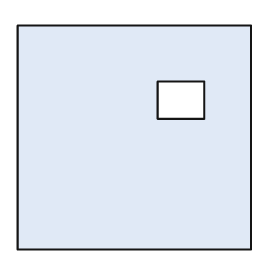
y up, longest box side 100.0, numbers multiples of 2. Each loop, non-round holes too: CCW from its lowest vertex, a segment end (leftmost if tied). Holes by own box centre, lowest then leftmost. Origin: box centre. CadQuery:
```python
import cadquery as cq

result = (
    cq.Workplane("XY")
    .moveTo(-50.0, -48.0)
    .lineTo(50.0, -48.0)
    .lineTo(50.0, 48.0)
    .lineTo(-50.0, 48.0)
    .close()
    .moveTo(10.0, 8.0)
    .lineTo(30.0, 8.0)
    .lineTo(30.0, 24.0)
    .lineTo(10.0, 24.0)
    .close()
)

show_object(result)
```